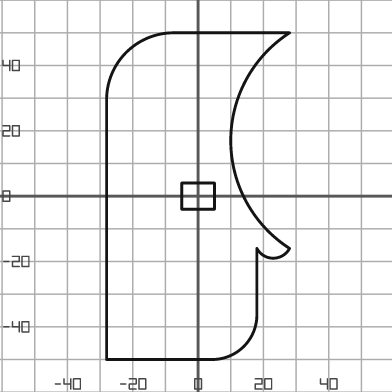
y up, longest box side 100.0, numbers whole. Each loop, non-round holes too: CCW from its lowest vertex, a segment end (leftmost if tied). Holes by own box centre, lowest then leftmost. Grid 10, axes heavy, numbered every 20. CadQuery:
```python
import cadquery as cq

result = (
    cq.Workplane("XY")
    .moveTo(-28.0, -50.0)
    .lineTo(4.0, -50.0)
    .threePointArc((14.0, -46.0), (18.0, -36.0))
    .lineTo(18.0, -16.0)
    .threePointArc((23.0, -19.0), (28.0, -16.0))
    .threePointArc((10.0, 17.0), (28.0, 50.0))
    .lineTo(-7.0, 50.0)
    .threePointArc((-22.0, 44.0), (-28.0, 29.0))
    .close()
    .moveTo(-5.0, -4.0)
    .lineTo(5.0, -4.0)
    .lineTo(5.0, 4.0)
    .lineTo(-5.0, 4.0)
    .close()
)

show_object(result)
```